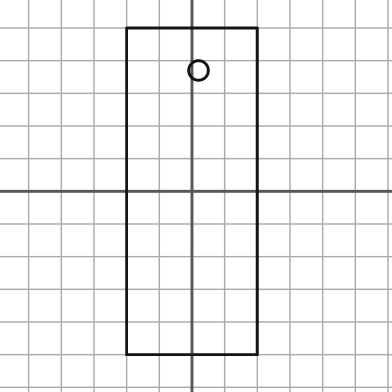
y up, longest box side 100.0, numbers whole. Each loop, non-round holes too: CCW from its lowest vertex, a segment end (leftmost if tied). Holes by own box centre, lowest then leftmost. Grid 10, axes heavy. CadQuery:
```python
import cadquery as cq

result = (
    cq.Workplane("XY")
    .moveTo(-20.0, -50.0)
    .lineTo(20.0, -50.0)
    .lineTo(20.0, 50.0)
    .lineTo(-20.0, 50.0)
    .close()
    .moveTo(2.0, 37.0)
    .circle(3.0)
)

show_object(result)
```